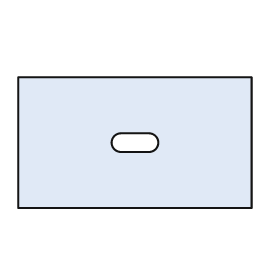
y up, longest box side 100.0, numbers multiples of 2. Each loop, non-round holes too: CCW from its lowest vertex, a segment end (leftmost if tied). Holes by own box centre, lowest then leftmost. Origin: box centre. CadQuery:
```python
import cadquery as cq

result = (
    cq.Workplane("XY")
    .moveTo(-50.0, -28.0)
    .lineTo(50.0, -28.0)
    .lineTo(50.0, 28.0)
    .lineTo(-50.0, 28.0)
    .close()
    .moveTo(-6.0, -4.0)
    .lineTo(6.0, -4.0)
    .threePointArc((10.0, 0.0), (6.0, 4.0))
    .lineTo(-6.0, 4.0)
    .threePointArc((-10.0, 0.0), (-6.0, -4.0))
    .close()
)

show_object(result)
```